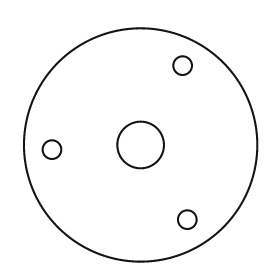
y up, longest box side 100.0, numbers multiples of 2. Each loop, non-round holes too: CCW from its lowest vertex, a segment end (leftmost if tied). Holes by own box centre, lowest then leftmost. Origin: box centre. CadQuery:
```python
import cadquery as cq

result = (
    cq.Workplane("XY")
    .moveTo(0.0, 0.0)
    .circle(50.0)
    .moveTo(20.0, -32.0)
    .circle(4.0)
    .moveTo(-38.0, -2.0)
    .circle(4.0)
    .moveTo(0.0, 0.0)
    .circle(10.0)
    .moveTo(18.0, 34.0)
    .circle(4.0)
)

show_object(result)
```